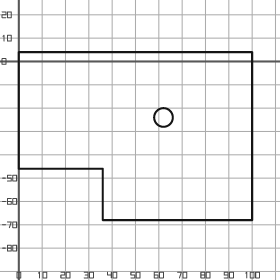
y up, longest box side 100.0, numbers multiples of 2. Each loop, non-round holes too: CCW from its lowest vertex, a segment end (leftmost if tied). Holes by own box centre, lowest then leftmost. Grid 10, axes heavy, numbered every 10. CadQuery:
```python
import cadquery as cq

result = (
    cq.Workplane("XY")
    .moveTo(36.0, -68.0)
    .lineTo(100.0, -68.0)
    .lineTo(100.0, 4.0)
    .lineTo(0.0, 4.0)
    .lineTo(0.0, -46.0)
    .lineTo(36.0, -46.0)
    .close()
    .moveTo(62.0, -24.0)
    .circle(4.0)
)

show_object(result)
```